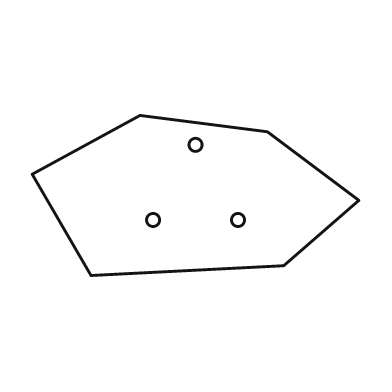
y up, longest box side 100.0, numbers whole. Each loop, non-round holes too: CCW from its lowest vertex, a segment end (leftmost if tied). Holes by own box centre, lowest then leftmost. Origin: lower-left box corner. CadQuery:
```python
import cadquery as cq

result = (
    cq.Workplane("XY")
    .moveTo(18.0, 0.0)
    .lineTo(77.0, 3.0)
    .lineTo(100.0, 23.0)
    .lineTo(72.0, 44.0)
    .lineTo(33.0, 49.0)
    .lineTo(0.0, 31.0)
    .close()
    .moveTo(37.0, 17.0)
    .circle(2.0)
    .moveTo(63.0, 17.0)
    .circle(2.0)
    .moveTo(50.0, 40.0)
    .circle(2.0)
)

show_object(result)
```